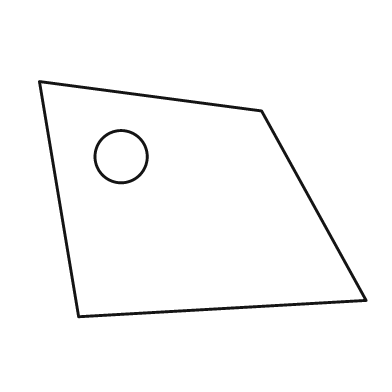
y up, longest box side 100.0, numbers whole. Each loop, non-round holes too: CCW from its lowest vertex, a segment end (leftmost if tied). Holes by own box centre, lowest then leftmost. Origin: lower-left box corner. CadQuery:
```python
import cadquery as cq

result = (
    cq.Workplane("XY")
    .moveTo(12.0, 0.0)
    .lineTo(100.0, 5.0)
    .lineTo(68.0, 63.0)
    .lineTo(0.0, 72.0)
    .close()
    .moveTo(25.0, 49.0)
    .circle(8.0)
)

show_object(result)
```